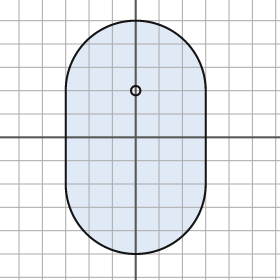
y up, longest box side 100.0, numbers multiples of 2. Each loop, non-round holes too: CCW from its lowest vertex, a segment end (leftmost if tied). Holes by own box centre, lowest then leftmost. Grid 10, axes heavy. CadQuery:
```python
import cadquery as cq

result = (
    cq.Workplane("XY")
    .moveTo(-30.0, -20.0)
    .threePointArc((0.0, -50.0), (30.0, -20.0))
    .lineTo(30.0, 20.0)
    .threePointArc((0.0, 50.0), (-30.0, 20.0))
    .close()
    .moveTo(0.0, 20.0)
    .circle(2.0)
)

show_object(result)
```